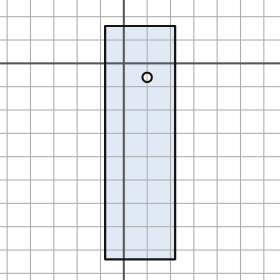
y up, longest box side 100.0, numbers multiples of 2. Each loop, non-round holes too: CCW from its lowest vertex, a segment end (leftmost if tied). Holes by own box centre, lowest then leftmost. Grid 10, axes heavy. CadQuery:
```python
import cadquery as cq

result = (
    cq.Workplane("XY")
    .moveTo(-8.0, -84.0)
    .lineTo(22.0, -84.0)
    .lineTo(22.0, 16.0)
    .lineTo(-8.0, 16.0)
    .close()
    .moveTo(10.0, -6.0)
    .circle(2.0)
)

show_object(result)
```